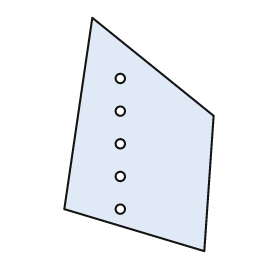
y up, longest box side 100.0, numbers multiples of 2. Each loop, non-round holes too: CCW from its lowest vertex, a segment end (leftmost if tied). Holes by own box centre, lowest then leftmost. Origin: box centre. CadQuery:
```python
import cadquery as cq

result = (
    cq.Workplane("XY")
    .moveTo(28.0, -50.0)
    .lineTo(32.0, 8.0)
    .lineTo(-20.0, 50.0)
    .lineTo(-32.0, -32.0)
    .close()
    .moveTo(-8.0, -32.0)
    .circle(2.0)
    .moveTo(-8.0, -18.0)
    .circle(2.0)
    .moveTo(-8.0, -4.0)
    .circle(2.0)
    .moveTo(-8.0, 10.0)
    .circle(2.0)
    .moveTo(-8.0, 24.0)
    .circle(2.0)
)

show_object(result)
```